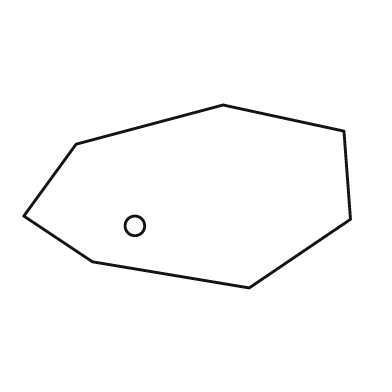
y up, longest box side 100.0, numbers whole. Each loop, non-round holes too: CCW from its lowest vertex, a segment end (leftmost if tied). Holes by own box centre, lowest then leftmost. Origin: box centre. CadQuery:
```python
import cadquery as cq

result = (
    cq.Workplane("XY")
    .moveTo(19.0, -28.0)
    .lineTo(50.0, -7.0)
    .lineTo(48.0, 20.0)
    .lineTo(11.0, 28.0)
    .lineTo(-34.0, 16.0)
    .lineTo(-50.0, -6.0)
    .lineTo(-29.0, -20.0)
    .close()
    .moveTo(-16.0, -9.0)
    .circle(3.0)
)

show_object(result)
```